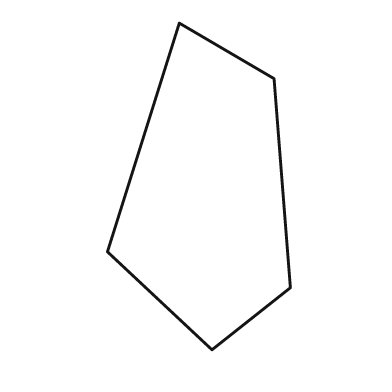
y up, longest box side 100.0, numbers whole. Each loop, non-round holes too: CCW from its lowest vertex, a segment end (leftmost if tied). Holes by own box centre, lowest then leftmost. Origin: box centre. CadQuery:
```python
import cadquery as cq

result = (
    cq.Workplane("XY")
    .moveTo(4.0, -50.0)
    .lineTo(28.0, -31.0)
    .lineTo(23.0, 33.0)
    .lineTo(-6.0, 50.0)
    .lineTo(-28.0, -20.0)
    .close()
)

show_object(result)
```